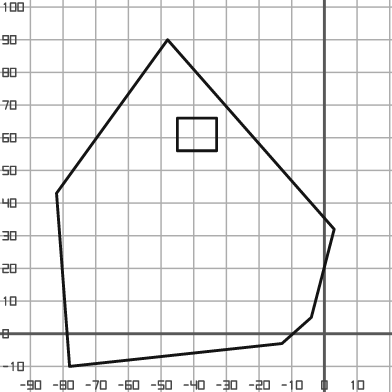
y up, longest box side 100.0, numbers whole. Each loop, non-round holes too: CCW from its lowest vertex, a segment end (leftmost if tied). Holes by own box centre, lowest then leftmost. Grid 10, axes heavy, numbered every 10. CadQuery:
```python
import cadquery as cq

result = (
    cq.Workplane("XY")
    .moveTo(-78.0, -10.0)
    .lineTo(-13.0, -3.0)
    .lineTo(-4.0, 5.0)
    .lineTo(3.0, 32.0)
    .lineTo(-48.0, 90.0)
    .lineTo(-82.0, 43.0)
    .close()
    .moveTo(-45.0, 56.0)
    .lineTo(-33.0, 56.0)
    .lineTo(-33.0, 66.0)
    .lineTo(-45.0, 66.0)
    .close()
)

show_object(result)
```